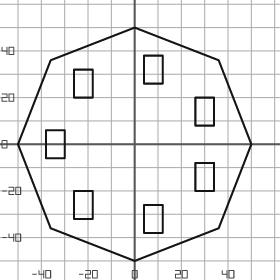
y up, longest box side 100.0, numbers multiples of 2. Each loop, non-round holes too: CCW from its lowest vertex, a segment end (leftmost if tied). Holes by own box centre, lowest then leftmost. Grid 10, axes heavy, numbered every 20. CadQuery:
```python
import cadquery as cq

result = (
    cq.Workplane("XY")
    .moveTo(0.0, -50.0)
    .lineTo(36.0, -36.0)
    .lineTo(50.0, 0.0)
    .lineTo(36.0, 36.0)
    .lineTo(0.0, 50.0)
    .lineTo(-36.0, 36.0)
    .lineTo(-50.0, 0.0)
    .lineTo(-36.0, -36.0)
    .close()
    .moveTo(4.0, -38.0)
    .lineTo(12.0, -38.0)
    .lineTo(12.0, -26.0)
    .lineTo(4.0, -26.0)
    .close()
    .moveTo(-26.0, -32.0)
    .lineTo(-18.0, -32.0)
    .lineTo(-18.0, -20.0)
    .lineTo(-26.0, -20.0)
    .close()
    .moveTo(26.0, -20.0)
    .lineTo(34.0, -20.0)
    .lineTo(34.0, -8.0)
    .lineTo(26.0, -8.0)
    .close()
    .moveTo(-38.0, -6.0)
    .lineTo(-30.0, -6.0)
    .lineTo(-30.0, 6.0)
    .lineTo(-38.0, 6.0)
    .close()
    .moveTo(26.0, 8.0)
    .lineTo(34.0, 8.0)
    .lineTo(34.0, 20.0)
    .lineTo(26.0, 20.0)
    .close()
    .moveTo(-26.0, 20.0)
    .lineTo(-18.0, 20.0)
    .lineTo(-18.0, 32.0)
    .lineTo(-26.0, 32.0)
    .close()
    .moveTo(4.0, 26.0)
    .lineTo(12.0, 26.0)
    .lineTo(12.0, 38.0)
    .lineTo(4.0, 38.0)
    .close()
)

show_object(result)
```